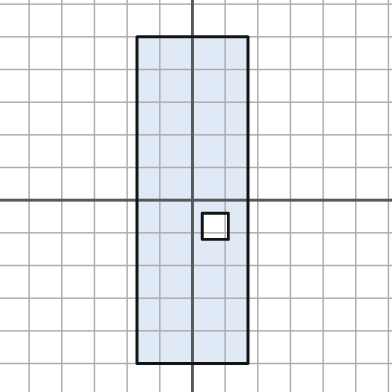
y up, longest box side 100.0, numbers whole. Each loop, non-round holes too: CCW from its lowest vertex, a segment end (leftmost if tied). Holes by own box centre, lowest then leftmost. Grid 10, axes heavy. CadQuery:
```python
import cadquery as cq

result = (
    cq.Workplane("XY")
    .moveTo(-17.0, -50.0)
    .lineTo(17.0, -50.0)
    .lineTo(17.0, 50.0)
    .lineTo(-17.0, 50.0)
    .close()
    .moveTo(3.0, -12.0)
    .lineTo(11.0, -12.0)
    .lineTo(11.0, -4.0)
    .lineTo(3.0, -4.0)
    .close()
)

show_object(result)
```